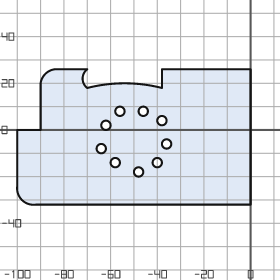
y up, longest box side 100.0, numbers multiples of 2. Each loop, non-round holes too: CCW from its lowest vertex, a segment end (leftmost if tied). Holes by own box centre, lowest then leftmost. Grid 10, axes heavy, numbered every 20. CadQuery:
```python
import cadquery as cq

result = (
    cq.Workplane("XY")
    .moveTo(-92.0, -32.0)
    .lineTo(0.0, -32.0)
    .lineTo(0.0, 26.0)
    .lineTo(-38.0, 26.0)
    .lineTo(-38.0, 18.0)
    .threePointArc((-54.0, 20.0), (-70.0, 18.0))
    .threePointArc((-72.0, 22.0), (-70.0, 26.0))
    .lineTo(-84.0, 26.0)
    .threePointArc((-88.0, 24.0), (-90.0, 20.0))
    .lineTo(-90.0, 0.0)
    .lineTo(-100.0, 0.0)
    .lineTo(-100.0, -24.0)
    .threePointArc((-98.0, -30.0), (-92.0, -32.0))
    .close()
    .moveTo(-48.0, -18.0)
    .circle(2.0)
    .moveTo(-58.0, -14.0)
    .circle(2.0)
    .moveTo(-40.0, -14.0)
    .circle(2.0)
    .moveTo(-64.0, -8.0)
    .circle(2.0)
    .moveTo(-36.0, -6.0)
    .circle(2.0)
    .moveTo(-62.0, 2.0)
    .circle(2.0)
    .moveTo(-38.0, 4.0)
    .circle(2.0)
    .moveTo(-56.0, 8.0)
    .circle(2.0)
    .moveTo(-46.0, 8.0)
    .circle(2.0)
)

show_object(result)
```